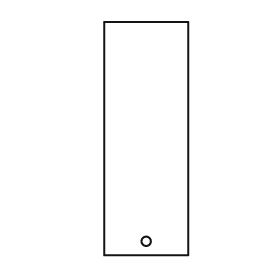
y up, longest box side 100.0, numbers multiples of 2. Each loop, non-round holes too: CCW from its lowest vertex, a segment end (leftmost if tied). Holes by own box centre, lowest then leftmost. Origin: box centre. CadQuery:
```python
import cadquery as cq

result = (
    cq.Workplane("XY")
    .moveTo(-18.0, -50.0)
    .lineTo(18.0, -50.0)
    .lineTo(18.0, 50.0)
    .lineTo(-18.0, 50.0)
    .close()
    .moveTo(0.0, -44.0)
    .circle(2.0)
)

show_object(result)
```